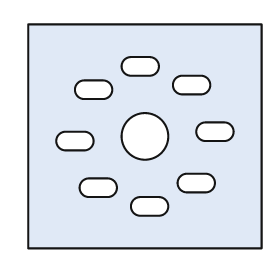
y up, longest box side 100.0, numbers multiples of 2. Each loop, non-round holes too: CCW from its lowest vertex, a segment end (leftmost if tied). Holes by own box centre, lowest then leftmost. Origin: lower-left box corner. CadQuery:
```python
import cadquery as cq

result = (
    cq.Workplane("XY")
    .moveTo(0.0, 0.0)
    .lineTo(100.0, 0.0)
    .lineTo(100.0, 96.0)
    .lineTo(0.0, 96.0)
    .close()
    .moveTo(48.0, 14.0)
    .lineTo(56.0, 14.0)
    .threePointArc((60.0, 18.0), (56.0, 22.0))
    .lineTo(48.0, 22.0)
    .threePointArc((44.0, 18.0), (48.0, 14.0))
    .close()
    .moveTo(26.0, 22.0)
    .lineTo(34.0, 22.0)
    .threePointArc((38.0, 26.0), (34.0, 30.0))
    .lineTo(26.0, 30.0)
    .threePointArc((22.0, 26.0), (26.0, 22.0))
    .close()
    .moveTo(68.0, 24.0)
    .lineTo(76.0, 24.0)
    .threePointArc((80.0, 28.0), (76.0, 32.0))
    .lineTo(68.0, 32.0)
    .threePointArc((64.0, 28.0), (68.0, 24.0))
    .close()
    .moveTo(16.0, 42.0)
    .lineTo(24.0, 42.0)
    .threePointArc((28.0, 46.0), (24.0, 50.0))
    .lineTo(16.0, 50.0)
    .threePointArc((12.0, 46.0), (16.0, 42.0))
    .close()
    .moveTo(50.0, 48.0)
    .circle(10.0)
    .moveTo(76.0, 46.0)
    .lineTo(84.0, 46.0)
    .threePointArc((88.0, 50.0), (84.0, 54.0))
    .lineTo(76.0, 54.0)
    .threePointArc((72.0, 50.0), (76.0, 46.0))
    .close()
    .moveTo(24.0, 64.0)
    .lineTo(32.0, 64.0)
    .threePointArc((36.0, 68.0), (32.0, 72.0))
    .lineTo(24.0, 72.0)
    .threePointArc((20.0, 68.0), (24.0, 64.0))
    .close()
    .moveTo(66.0, 66.0)
    .lineTo(74.0, 66.0)
    .threePointArc((78.0, 70.0), (74.0, 74.0))
    .lineTo(66.0, 74.0)
    .threePointArc((62.0, 70.0), (66.0, 66.0))
    .close()
    .moveTo(44.0, 74.0)
    .lineTo(52.0, 74.0)
    .threePointArc((56.0, 78.0), (52.0, 82.0))
    .lineTo(44.0, 82.0)
    .threePointArc((40.0, 78.0), (44.0, 74.0))
    .close()
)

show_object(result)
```